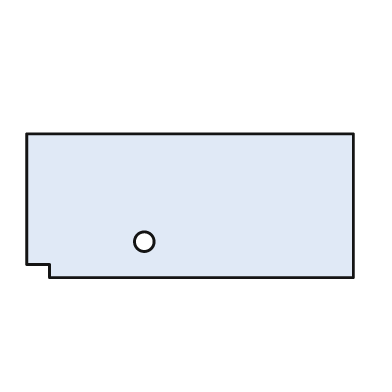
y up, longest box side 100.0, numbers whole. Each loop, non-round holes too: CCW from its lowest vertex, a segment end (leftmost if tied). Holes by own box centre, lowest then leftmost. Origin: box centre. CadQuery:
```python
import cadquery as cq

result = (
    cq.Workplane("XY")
    .moveTo(-43.0, -22.0)
    .lineTo(50.0, -22.0)
    .lineTo(50.0, 22.0)
    .lineTo(-50.0, 22.0)
    .lineTo(-50.0, -18.0)
    .lineTo(-43.0, -18.0)
    .close()
    .moveTo(-14.0, -11.0)
    .circle(3.0)
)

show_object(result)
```